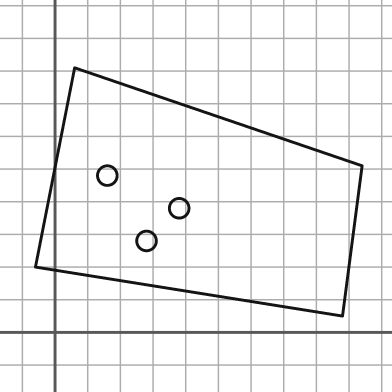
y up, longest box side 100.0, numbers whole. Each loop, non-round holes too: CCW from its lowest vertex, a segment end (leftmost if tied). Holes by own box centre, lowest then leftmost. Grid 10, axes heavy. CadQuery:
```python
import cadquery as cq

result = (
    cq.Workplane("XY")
    .moveTo(88.0, 5.0)
    .lineTo(94.0, 51.0)
    .lineTo(6.0, 81.0)
    .lineTo(-6.0, 20.0)
    .close()
    .moveTo(28.0, 28.0)
    .circle(3.0)
    .moveTo(38.0, 38.0)
    .circle(3.0)
    .moveTo(16.0, 48.0)
    .circle(3.0)
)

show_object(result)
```